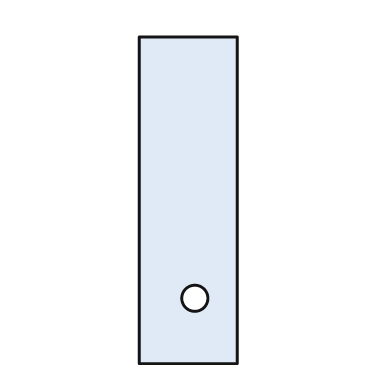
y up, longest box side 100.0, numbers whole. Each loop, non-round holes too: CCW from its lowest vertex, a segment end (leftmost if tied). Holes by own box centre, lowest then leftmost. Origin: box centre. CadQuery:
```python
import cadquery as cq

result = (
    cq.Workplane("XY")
    .moveTo(-15.0, -50.0)
    .lineTo(15.0, -50.0)
    .lineTo(15.0, 50.0)
    .lineTo(-15.0, 50.0)
    .close()
    .moveTo(2.0, -30.0)
    .circle(4.0)
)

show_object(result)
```